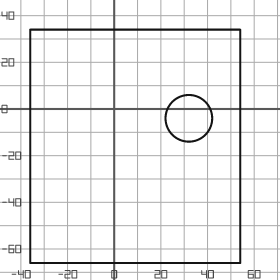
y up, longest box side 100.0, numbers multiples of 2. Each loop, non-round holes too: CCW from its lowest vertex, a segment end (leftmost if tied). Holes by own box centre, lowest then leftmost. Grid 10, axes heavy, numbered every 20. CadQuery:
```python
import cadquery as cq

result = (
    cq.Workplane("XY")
    .moveTo(-36.0, -66.0)
    .lineTo(54.0, -66.0)
    .lineTo(54.0, 34.0)
    .lineTo(-36.0, 34.0)
    .close()
    .moveTo(32.0, -4.0)
    .circle(10.0)
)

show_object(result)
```